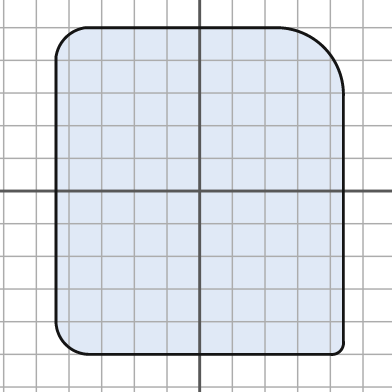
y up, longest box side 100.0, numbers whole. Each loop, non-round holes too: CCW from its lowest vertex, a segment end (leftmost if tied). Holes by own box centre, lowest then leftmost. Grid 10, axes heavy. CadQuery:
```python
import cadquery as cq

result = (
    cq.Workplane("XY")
    .moveTo(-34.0, -50.0)
    .lineTo(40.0, -50.0)
    .threePointArc((43.0, -49.0), (44.0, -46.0))
    .lineTo(44.0, 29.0)
    .threePointArc((38.0, 44.0), (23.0, 50.0))
    .lineTo(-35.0, 50.0)
    .threePointArc((-41.0, 47.0), (-44.0, 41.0))
    .lineTo(-44.0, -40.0)
    .threePointArc((-41.0, -47.0), (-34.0, -50.0))
    .close()
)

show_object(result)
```